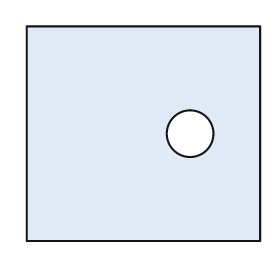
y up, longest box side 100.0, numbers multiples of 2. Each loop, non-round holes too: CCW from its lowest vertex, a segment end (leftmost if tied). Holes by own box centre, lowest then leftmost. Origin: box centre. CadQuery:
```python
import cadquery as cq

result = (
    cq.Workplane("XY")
    .moveTo(-50.0, -46.0)
    .lineTo(50.0, -46.0)
    .lineTo(50.0, 46.0)
    .lineTo(-50.0, 46.0)
    .close()
    .moveTo(20.0, 0.0)
    .circle(10.0)
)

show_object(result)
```